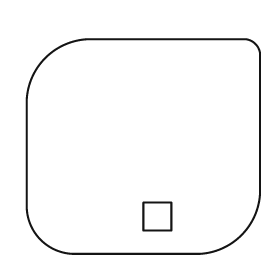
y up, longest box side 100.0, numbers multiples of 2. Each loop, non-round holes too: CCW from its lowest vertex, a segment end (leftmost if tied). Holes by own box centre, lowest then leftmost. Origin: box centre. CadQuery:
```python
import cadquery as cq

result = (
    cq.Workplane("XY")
    .moveTo(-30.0, -46.0)
    .lineTo(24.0, -46.0)
    .threePointArc((42.0, -38.0), (50.0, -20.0))
    .lineTo(50.0, 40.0)
    .threePointArc((48.0, 44.0), (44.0, 46.0))
    .lineTo(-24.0, 46.0)
    .threePointArc((-42.0, 38.0), (-50.0, 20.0))
    .lineTo(-50.0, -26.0)
    .threePointArc((-44.0, -40.0), (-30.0, -46.0))
    .close()
    .moveTo(0.0, -36.0)
    .lineTo(12.0, -36.0)
    .lineTo(12.0, -24.0)
    .lineTo(0.0, -24.0)
    .close()
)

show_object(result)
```